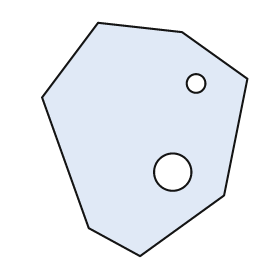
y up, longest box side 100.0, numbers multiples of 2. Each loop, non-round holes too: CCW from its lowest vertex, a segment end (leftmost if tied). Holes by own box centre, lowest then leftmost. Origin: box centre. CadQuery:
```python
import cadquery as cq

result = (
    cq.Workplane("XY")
    .moveTo(-2.0, -50.0)
    .lineTo(34.0, -24.0)
    .lineTo(44.0, 26.0)
    .lineTo(16.0, 46.0)
    .lineTo(-20.0, 50.0)
    .lineTo(-44.0, 18.0)
    .lineTo(-24.0, -38.0)
    .close()
    .moveTo(12.0, -14.0)
    .circle(8.0)
    .moveTo(22.0, 24.0)
    .circle(4.0)
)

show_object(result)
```